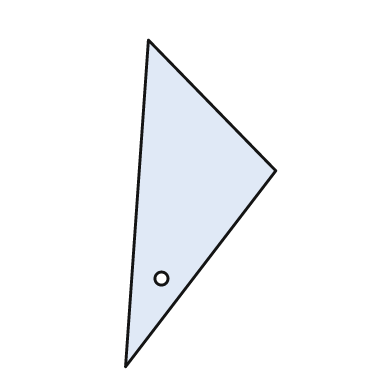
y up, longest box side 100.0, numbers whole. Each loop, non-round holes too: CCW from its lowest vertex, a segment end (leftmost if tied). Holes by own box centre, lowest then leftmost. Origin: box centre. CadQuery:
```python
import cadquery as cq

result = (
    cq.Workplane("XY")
    .moveTo(-23.0, -50.0)
    .lineTo(23.0, 10.0)
    .lineTo(-16.0, 50.0)
    .close()
    .moveTo(-12.0, -23.0)
    .circle(2.0)
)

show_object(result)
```